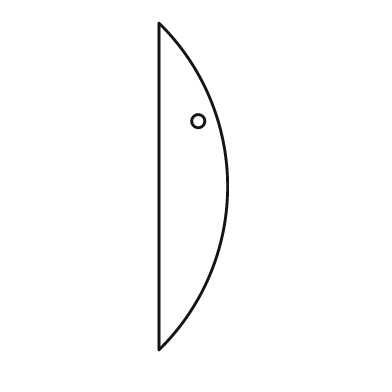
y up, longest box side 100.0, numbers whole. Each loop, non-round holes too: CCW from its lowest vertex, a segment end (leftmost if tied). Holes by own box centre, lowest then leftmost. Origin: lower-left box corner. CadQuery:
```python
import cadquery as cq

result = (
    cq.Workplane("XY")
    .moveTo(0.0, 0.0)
    .threePointArc((21.0, 50.0), (0.0, 100.0))
    .close()
    .moveTo(12.0, 70.0)
    .circle(2.0)
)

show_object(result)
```